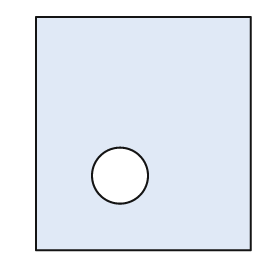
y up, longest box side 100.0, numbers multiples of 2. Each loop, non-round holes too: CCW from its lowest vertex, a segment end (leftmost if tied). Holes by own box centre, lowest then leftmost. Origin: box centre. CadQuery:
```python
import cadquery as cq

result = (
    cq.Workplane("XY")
    .moveTo(-46.0, -50.0)
    .lineTo(46.0, -50.0)
    .lineTo(46.0, 50.0)
    .lineTo(-46.0, 50.0)
    .close()
    .moveTo(-10.0, -18.0)
    .circle(12.0)
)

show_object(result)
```